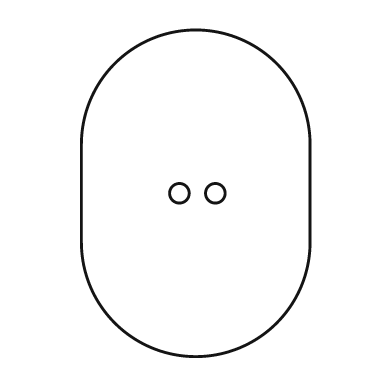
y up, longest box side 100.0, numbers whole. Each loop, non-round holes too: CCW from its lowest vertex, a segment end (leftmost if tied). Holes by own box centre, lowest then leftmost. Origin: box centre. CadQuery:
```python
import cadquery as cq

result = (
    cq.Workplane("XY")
    .moveTo(-35.0, -15.0)
    .threePointArc((0.0, -50.0), (35.0, -15.0))
    .lineTo(35.0, 15.0)
    .threePointArc((0.0, 50.0), (-35.0, 15.0))
    .close()
    .moveTo(-5.0, 0.0)
    .circle(3.0)
    .moveTo(6.0, 0.0)
    .circle(3.0)
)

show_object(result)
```